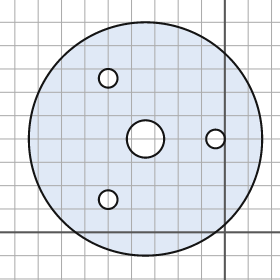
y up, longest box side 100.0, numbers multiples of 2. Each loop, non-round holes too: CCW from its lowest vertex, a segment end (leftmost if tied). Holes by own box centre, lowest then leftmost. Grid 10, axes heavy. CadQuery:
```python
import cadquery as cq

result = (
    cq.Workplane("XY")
    .moveTo(-34.0, 40.0)
    .circle(50.0)
    .moveTo(-50.0, 14.0)
    .circle(4.0)
    .moveTo(-34.0, 40.0)
    .circle(8.0)
    .moveTo(-4.0, 40.0)
    .circle(4.0)
    .moveTo(-50.0, 66.0)
    .circle(4.0)
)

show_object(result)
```